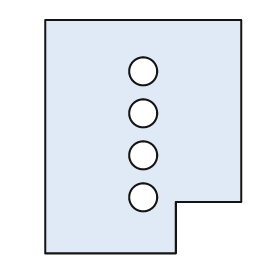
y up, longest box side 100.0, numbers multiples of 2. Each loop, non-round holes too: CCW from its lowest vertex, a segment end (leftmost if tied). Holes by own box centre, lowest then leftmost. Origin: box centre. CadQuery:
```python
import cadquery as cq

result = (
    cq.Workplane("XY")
    .moveTo(-42.0, -50.0)
    .lineTo(14.0, -50.0)
    .lineTo(14.0, -28.0)
    .lineTo(42.0, -28.0)
    .lineTo(42.0, 50.0)
    .lineTo(-42.0, 50.0)
    .close()
    .moveTo(0.0, -26.0)
    .circle(6.0)
    .moveTo(0.0, -8.0)
    .circle(6.0)
    .moveTo(0.0, 10.0)
    .circle(6.0)
    .moveTo(0.0, 28.0)
    .circle(6.0)
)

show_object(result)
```